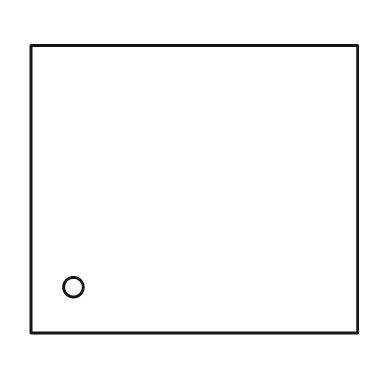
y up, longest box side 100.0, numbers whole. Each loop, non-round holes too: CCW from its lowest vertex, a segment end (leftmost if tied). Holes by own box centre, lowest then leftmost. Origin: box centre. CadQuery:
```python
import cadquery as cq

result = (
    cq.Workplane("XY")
    .moveTo(-50.0, -44.0)
    .lineTo(50.0, -44.0)
    .lineTo(50.0, 44.0)
    .lineTo(-50.0, 44.0)
    .close()
    .moveTo(-37.0, -30.0)
    .circle(3.0)
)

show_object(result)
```